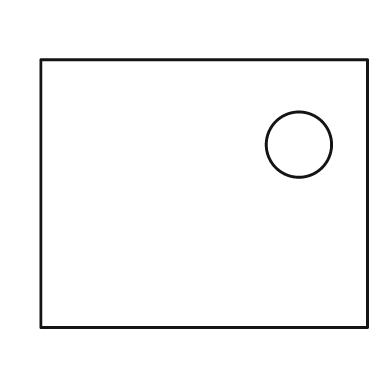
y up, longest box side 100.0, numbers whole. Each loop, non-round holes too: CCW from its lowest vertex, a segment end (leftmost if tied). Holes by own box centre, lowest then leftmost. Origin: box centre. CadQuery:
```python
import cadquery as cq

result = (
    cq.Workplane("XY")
    .moveTo(-50.0, -41.0)
    .lineTo(50.0, -41.0)
    .lineTo(50.0, 41.0)
    .lineTo(-50.0, 41.0)
    .close()
    .moveTo(29.0, 15.0)
    .circle(10.0)
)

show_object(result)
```